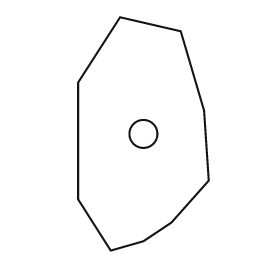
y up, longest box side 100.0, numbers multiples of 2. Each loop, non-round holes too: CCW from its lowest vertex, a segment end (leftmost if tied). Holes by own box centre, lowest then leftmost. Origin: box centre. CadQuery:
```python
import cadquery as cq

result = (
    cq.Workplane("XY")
    .moveTo(-14.0, -50.0)
    .lineTo(0.0, -46.0)
    .lineTo(12.0, -38.0)
    .lineTo(28.0, -20.0)
    .lineTo(26.0, 10.0)
    .lineTo(16.0, 44.0)
    .lineTo(-10.0, 50.0)
    .lineTo(-28.0, 22.0)
    .lineTo(-28.0, -28.0)
    .close()
    .moveTo(0.0, 0.0)
    .circle(6.0)
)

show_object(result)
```